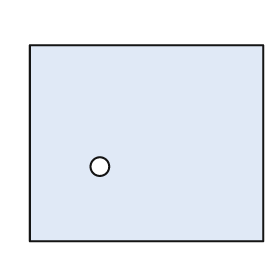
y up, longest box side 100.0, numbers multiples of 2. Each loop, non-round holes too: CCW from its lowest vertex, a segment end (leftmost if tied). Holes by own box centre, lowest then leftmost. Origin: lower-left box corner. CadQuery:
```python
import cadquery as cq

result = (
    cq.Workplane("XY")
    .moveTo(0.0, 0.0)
    .lineTo(100.0, 0.0)
    .lineTo(100.0, 84.0)
    .lineTo(0.0, 84.0)
    .close()
    .moveTo(30.0, 32.0)
    .circle(4.0)
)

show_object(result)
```